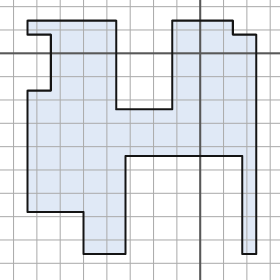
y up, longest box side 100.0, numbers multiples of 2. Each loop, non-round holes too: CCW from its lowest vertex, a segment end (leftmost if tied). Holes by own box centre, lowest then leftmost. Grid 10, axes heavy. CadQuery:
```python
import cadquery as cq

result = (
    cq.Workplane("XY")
    .moveTo(-50.0, -86.0)
    .lineTo(-32.0, -86.0)
    .lineTo(-32.0, -44.0)
    .lineTo(18.0, -44.0)
    .lineTo(18.0, -86.0)
    .lineTo(24.0, -86.0)
    .lineTo(24.0, 8.0)
    .lineTo(14.0, 8.0)
    .lineTo(14.0, 14.0)
    .lineTo(-12.0, 14.0)
    .lineTo(-12.0, -24.0)
    .lineTo(-36.0, -24.0)
    .lineTo(-36.0, 14.0)
    .lineTo(-74.0, 14.0)
    .lineTo(-74.0, 8.0)
    .lineTo(-64.0, 8.0)
    .lineTo(-64.0, -16.0)
    .lineTo(-74.0, -16.0)
    .lineTo(-74.0, -68.0)
    .lineTo(-50.0, -68.0)
    .close()
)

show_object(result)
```